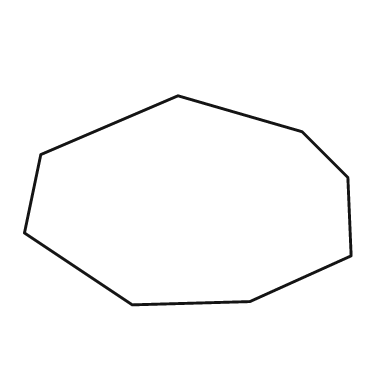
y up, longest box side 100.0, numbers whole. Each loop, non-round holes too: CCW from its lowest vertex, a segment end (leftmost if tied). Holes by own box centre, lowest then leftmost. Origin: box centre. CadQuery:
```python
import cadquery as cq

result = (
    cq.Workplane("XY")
    .moveTo(-17.0, -32.0)
    .lineTo(19.0, -31.0)
    .lineTo(50.0, -17.0)
    .lineTo(49.0, 7.0)
    .lineTo(35.0, 21.0)
    .lineTo(-3.0, 32.0)
    .lineTo(-45.0, 14.0)
    .lineTo(-50.0, -10.0)
    .close()
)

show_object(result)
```